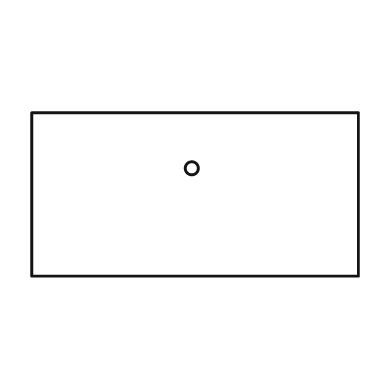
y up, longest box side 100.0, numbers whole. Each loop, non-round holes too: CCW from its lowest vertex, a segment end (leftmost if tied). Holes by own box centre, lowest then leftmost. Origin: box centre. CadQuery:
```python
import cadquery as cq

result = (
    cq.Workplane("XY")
    .moveTo(-50.0, -25.0)
    .lineTo(50.0, -25.0)
    .lineTo(50.0, 25.0)
    .lineTo(-50.0, 25.0)
    .close()
    .moveTo(-1.0, 8.0)
    .circle(2.0)
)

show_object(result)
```